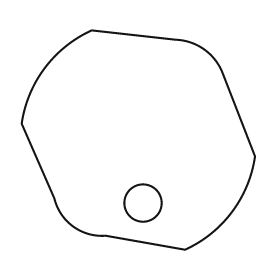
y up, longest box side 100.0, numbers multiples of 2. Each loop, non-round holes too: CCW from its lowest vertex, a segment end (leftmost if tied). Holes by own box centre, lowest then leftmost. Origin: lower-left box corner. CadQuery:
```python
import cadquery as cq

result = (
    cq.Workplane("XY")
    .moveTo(70.0, 0.0)
    .threePointArc((90.0, 16.0), (100.0, 40.0))
    .lineTo(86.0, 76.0)
    .threePointArc((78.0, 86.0), (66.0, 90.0))
    .lineTo(30.0, 94.0)
    .threePointArc((10.0, 78.0), (0.0, 54.0))
    .lineTo(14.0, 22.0)
    .threePointArc((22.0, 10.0), (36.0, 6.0))
    .close()
    .moveTo(52.0, 20.0)
    .circle(8.0)
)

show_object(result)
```